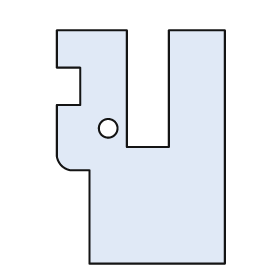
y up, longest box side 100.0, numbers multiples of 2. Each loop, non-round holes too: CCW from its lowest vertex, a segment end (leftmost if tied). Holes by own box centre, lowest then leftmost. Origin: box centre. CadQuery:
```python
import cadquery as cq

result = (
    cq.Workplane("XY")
    .moveTo(-22.0, -50.0)
    .lineTo(36.0, -50.0)
    .lineTo(36.0, 50.0)
    .lineTo(12.0, 50.0)
    .lineTo(12.0, 0.0)
    .lineTo(-6.0, 0.0)
    .lineTo(-6.0, 50.0)
    .lineTo(-36.0, 50.0)
    .lineTo(-36.0, 34.0)
    .lineTo(-26.0, 34.0)
    .lineTo(-26.0, 18.0)
    .lineTo(-36.0, 18.0)
    .lineTo(-36.0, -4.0)
    .threePointArc((-34.0, -8.0), (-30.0, -10.0))
    .lineTo(-22.0, -10.0)
    .close()
    .moveTo(-14.0, 8.0)
    .circle(4.0)
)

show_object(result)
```